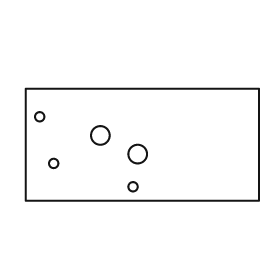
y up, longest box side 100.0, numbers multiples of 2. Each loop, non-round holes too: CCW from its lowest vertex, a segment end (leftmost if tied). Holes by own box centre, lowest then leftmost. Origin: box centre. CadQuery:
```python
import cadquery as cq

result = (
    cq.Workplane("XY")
    .moveTo(-50.0, -24.0)
    .lineTo(50.0, -24.0)
    .lineTo(50.0, 24.0)
    .lineTo(-50.0, 24.0)
    .close()
    .moveTo(-4.0, -18.0)
    .circle(2.0)
    .moveTo(-38.0, -8.0)
    .circle(2.0)
    .moveTo(-2.0, -4.0)
    .circle(4.0)
    .moveTo(-18.0, 4.0)
    .circle(4.0)
    .moveTo(-44.0, 12.0)
    .circle(2.0)
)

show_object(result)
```